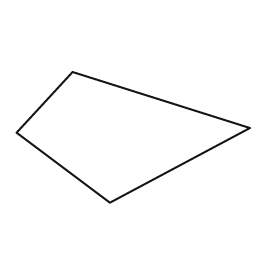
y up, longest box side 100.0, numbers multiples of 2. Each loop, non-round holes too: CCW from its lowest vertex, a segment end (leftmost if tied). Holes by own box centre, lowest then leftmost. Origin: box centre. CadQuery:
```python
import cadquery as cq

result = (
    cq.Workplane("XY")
    .moveTo(-10.0, -28.0)
    .lineTo(50.0, 4.0)
    .lineTo(-26.0, 28.0)
    .lineTo(-50.0, 2.0)
    .close()
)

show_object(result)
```